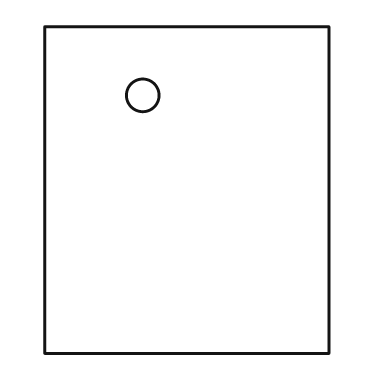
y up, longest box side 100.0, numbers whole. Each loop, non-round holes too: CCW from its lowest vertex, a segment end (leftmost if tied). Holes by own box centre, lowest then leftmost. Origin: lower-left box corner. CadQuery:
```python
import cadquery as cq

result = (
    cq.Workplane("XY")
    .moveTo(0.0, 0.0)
    .lineTo(87.0, 0.0)
    .lineTo(87.0, 100.0)
    .lineTo(0.0, 100.0)
    .close()
    .moveTo(30.0, 79.0)
    .circle(5.0)
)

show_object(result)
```